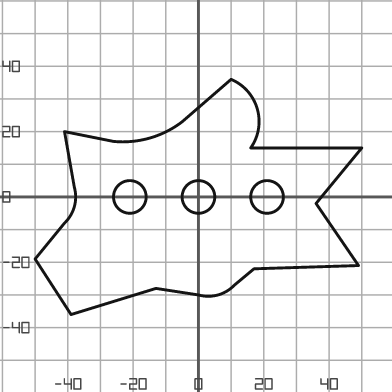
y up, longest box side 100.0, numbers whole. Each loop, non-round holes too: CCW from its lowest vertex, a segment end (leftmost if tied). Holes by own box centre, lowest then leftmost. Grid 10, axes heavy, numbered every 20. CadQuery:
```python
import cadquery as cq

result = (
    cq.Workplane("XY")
    .moveTo(-39.0, -36.0)
    .lineTo(-13.0, -28.0)
    .lineTo(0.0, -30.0)
    .threePointArc((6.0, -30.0), (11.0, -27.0))
    .lineTo(17.0, -22.0)
    .lineTo(49.0, -21.0)
    .lineTo(36.0, -2.0)
    .lineTo(50.0, 15.0)
    .lineTo(16.0, 15.0)
    .threePointArc((18.0, 27.0), (10.0, 36.0))
    .lineTo(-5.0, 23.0)
    .threePointArc((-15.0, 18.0), (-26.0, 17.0))
    .lineTo(-41.0, 20.0)
    .lineTo(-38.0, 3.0)
    .threePointArc((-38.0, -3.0), (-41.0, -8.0))
    .lineTo(-50.0, -19.0)
    .close()
    .moveTo(-21.0, 0.0)
    .circle(5.0)
    .moveTo(0.0, 0.0)
    .circle(5.0)
    .moveTo(21.0, 0.0)
    .circle(5.0)
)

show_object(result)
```